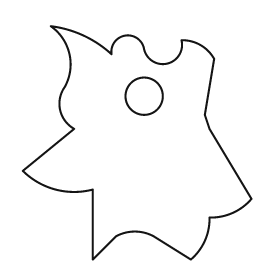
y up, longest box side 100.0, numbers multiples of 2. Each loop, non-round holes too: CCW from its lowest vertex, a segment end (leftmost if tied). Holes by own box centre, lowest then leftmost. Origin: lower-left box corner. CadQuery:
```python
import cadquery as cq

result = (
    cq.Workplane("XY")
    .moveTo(30.0, 0.0)
    .lineTo(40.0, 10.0)
    .threePointArc((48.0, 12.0), (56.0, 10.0))
    .lineTo(72.0, 0.0)
    .threePointArc((78.0, 8.0), (80.0, 18.0))
    .threePointArc((90.0, 20.0), (98.0, 26.0))
    .lineTo(80.0, 56.0)
    .lineTo(78.0, 62.0)
    .lineTo(82.0, 86.0)
    .threePointArc((76.0, 92.0), (68.0, 94.0))
    .threePointArc((62.0, 84.0), (52.0, 90.0))
    .threePointArc((44.0, 96.0), (38.0, 88.0))
    .threePointArc((26.0, 96.0), (12.0, 100.0))
    .threePointArc((20.0, 88.0), (18.0, 74.0))
    .threePointArc((16.0, 64.0), (22.0, 56.0))
    .lineTo(0.0, 38.0)
    .threePointArc((14.0, 30.0), (30.0, 30.0))
    .close()
    .moveTo(52.0, 70.0)
    .circle(8.0)
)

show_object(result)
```